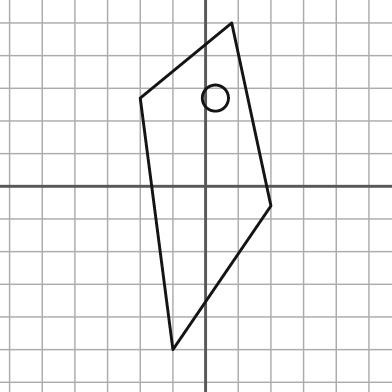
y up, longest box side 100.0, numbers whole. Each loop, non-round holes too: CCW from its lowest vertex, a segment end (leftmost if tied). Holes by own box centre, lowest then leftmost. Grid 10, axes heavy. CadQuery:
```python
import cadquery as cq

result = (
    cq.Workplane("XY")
    .moveTo(-10.0, -50.0)
    .lineTo(20.0, -6.0)
    .lineTo(8.0, 50.0)
    .lineTo(-20.0, 27.0)
    .close()
    .moveTo(3.0, 27.0)
    .circle(4.0)
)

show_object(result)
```